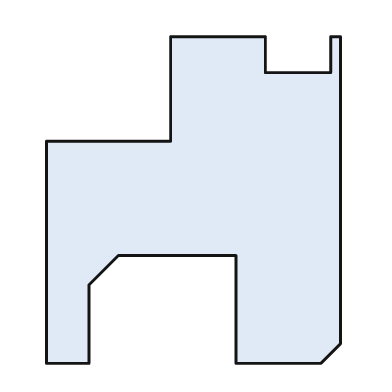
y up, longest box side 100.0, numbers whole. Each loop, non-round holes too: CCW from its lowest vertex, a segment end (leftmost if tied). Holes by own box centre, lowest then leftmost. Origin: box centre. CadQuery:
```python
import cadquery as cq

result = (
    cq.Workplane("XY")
    .moveTo(-45.0, -50.0)
    .lineTo(-32.0, -50.0)
    .lineTo(-32.0, -26.0)
    .lineTo(-23.0, -17.0)
    .lineTo(13.0, -17.0)
    .lineTo(13.0, -50.0)
    .lineTo(39.0, -50.0)
    .lineTo(45.0, -44.0)
    .lineTo(45.0, 50.0)
    .lineTo(42.0, 50.0)
    .lineTo(42.0, 39.0)
    .lineTo(22.0, 39.0)
    .lineTo(22.0, 50.0)
    .lineTo(-7.0, 50.0)
    .lineTo(-7.0, 18.0)
    .lineTo(-45.0, 18.0)
    .close()
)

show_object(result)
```